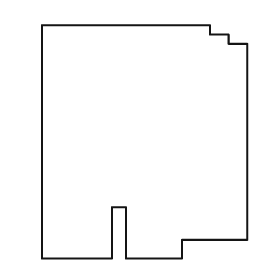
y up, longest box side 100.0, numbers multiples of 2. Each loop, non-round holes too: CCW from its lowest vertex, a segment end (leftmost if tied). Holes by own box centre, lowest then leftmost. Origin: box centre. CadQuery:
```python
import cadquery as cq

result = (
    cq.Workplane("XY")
    .moveTo(-44.0, -50.0)
    .lineTo(-14.0, -50.0)
    .lineTo(-14.0, -28.0)
    .lineTo(-8.0, -28.0)
    .lineTo(-8.0, -50.0)
    .lineTo(16.0, -50.0)
    .lineTo(16.0, -42.0)
    .lineTo(44.0, -42.0)
    .lineTo(44.0, 42.0)
    .lineTo(36.0, 42.0)
    .lineTo(36.0, 46.0)
    .lineTo(28.0, 46.0)
    .lineTo(28.0, 50.0)
    .lineTo(-44.0, 50.0)
    .close()
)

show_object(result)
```